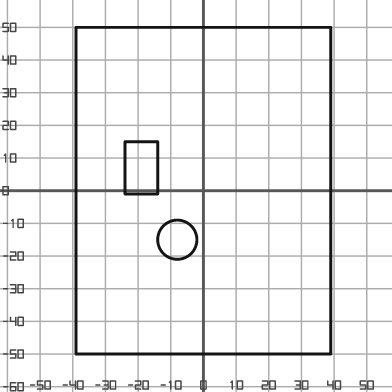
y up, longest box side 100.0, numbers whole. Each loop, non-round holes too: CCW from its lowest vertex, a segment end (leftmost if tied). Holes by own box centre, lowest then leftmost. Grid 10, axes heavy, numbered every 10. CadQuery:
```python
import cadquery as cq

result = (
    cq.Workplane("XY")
    .moveTo(-39.0, -50.0)
    .lineTo(39.0, -50.0)
    .lineTo(39.0, 50.0)
    .lineTo(-39.0, 50.0)
    .close()
    .moveTo(-8.0, -15.0)
    .circle(6.0)
    .moveTo(-24.0, -1.0)
    .lineTo(-14.0, -1.0)
    .lineTo(-14.0, 15.0)
    .lineTo(-24.0, 15.0)
    .close()
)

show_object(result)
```